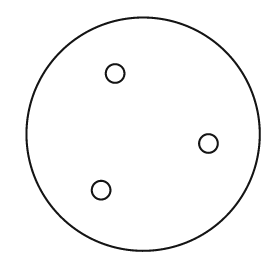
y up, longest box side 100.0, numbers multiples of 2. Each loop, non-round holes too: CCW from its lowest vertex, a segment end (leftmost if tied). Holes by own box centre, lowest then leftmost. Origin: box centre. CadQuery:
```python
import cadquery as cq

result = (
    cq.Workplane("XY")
    .moveTo(0.0, 0.0)
    .circle(50.0)
    .moveTo(-18.0, -24.0)
    .circle(4.0)
    .moveTo(28.0, -4.0)
    .circle(4.0)
    .moveTo(-12.0, 26.0)
    .circle(4.0)
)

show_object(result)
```